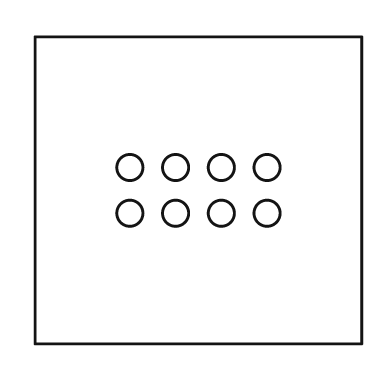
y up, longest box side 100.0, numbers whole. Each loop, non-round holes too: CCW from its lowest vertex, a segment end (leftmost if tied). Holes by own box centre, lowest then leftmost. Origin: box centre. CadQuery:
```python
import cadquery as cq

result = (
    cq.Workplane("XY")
    .moveTo(-50.0, -47.0)
    .lineTo(50.0, -47.0)
    .lineTo(50.0, 47.0)
    .lineTo(-50.0, 47.0)
    .close()
    .moveTo(-21.0, -7.0)
    .circle(4.0)
    .moveTo(-7.0, -7.0)
    .circle(4.0)
    .moveTo(7.0, -7.0)
    .circle(4.0)
    .moveTo(21.0, -7.0)
    .circle(4.0)
    .moveTo(-21.0, 7.0)
    .circle(4.0)
    .moveTo(-7.0, 7.0)
    .circle(4.0)
    .moveTo(7.0, 7.0)
    .circle(4.0)
    .moveTo(21.0, 7.0)
    .circle(4.0)
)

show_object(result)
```